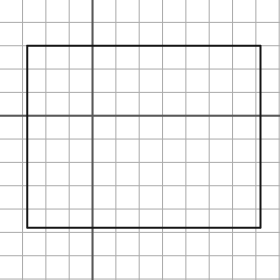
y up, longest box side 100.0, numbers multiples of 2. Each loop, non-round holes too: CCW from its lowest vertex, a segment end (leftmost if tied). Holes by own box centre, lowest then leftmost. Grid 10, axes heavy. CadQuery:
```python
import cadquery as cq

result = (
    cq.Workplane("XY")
    .moveTo(-28.0, -48.0)
    .lineTo(72.0, -48.0)
    .lineTo(72.0, 30.0)
    .lineTo(-28.0, 30.0)
    .close()
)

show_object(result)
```